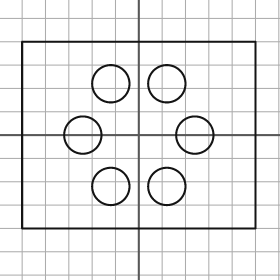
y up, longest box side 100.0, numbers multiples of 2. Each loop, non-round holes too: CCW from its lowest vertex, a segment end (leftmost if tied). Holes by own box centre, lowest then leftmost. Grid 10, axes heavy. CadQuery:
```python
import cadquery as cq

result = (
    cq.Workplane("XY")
    .moveTo(-50.0, -40.0)
    .lineTo(50.0, -40.0)
    .lineTo(50.0, 40.0)
    .lineTo(-50.0, 40.0)
    .close()
    .moveTo(-12.0, -22.0)
    .circle(8.0)
    .moveTo(12.0, -22.0)
    .circle(8.0)
    .moveTo(-24.0, 0.0)
    .circle(8.0)
    .moveTo(24.0, 0.0)
    .circle(8.0)
    .moveTo(-12.0, 22.0)
    .circle(8.0)
    .moveTo(12.0, 22.0)
    .circle(8.0)
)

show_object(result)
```